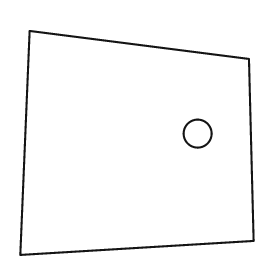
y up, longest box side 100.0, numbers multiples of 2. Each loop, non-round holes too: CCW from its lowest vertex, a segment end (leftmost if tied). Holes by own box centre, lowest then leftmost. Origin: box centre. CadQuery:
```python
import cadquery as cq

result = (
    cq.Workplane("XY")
    .moveTo(-50.0, -48.0)
    .lineTo(50.0, -42.0)
    .lineTo(48.0, 36.0)
    .lineTo(-46.0, 48.0)
    .close()
    .moveTo(26.0, 4.0)
    .circle(6.0)
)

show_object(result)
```